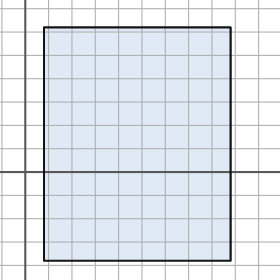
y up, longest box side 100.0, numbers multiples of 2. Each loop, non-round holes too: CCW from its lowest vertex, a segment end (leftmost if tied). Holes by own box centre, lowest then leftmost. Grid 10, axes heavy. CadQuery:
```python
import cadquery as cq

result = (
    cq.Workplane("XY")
    .moveTo(8.0, -38.0)
    .lineTo(88.0, -38.0)
    .lineTo(88.0, 62.0)
    .lineTo(8.0, 62.0)
    .close()
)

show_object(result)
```